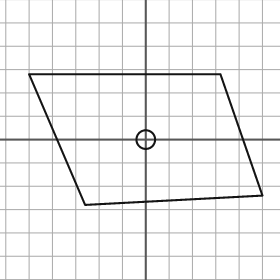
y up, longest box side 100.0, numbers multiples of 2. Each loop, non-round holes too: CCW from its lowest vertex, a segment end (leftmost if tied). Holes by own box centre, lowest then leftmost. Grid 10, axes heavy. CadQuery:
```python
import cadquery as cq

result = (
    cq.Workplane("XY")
    .moveTo(-26.0, -28.0)
    .lineTo(50.0, -24.0)
    .lineTo(32.0, 28.0)
    .lineTo(-50.0, 28.0)
    .close()
    .moveTo(0.0, 0.0)
    .circle(4.0)
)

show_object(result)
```